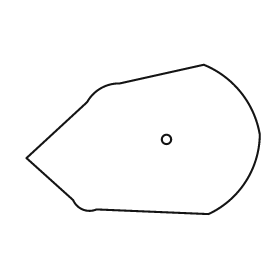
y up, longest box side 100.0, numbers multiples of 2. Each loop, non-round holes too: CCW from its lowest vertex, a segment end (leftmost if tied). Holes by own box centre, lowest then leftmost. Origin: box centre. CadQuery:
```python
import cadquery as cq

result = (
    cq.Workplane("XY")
    .moveTo(28.0, -32.0)
    .threePointArc((44.0, -18.0), (50.0, 2.0))
    .threePointArc((42.0, 20.0), (26.0, 32.0))
    .lineTo(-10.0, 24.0)
    .threePointArc((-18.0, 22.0), (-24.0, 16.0))
    .lineTo(-50.0, -8.0)
    .lineTo(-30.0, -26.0)
    .threePointArc((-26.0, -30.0), (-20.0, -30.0))
    .close()
    .moveTo(10.0, 0.0)
    .circle(2.0)
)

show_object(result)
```